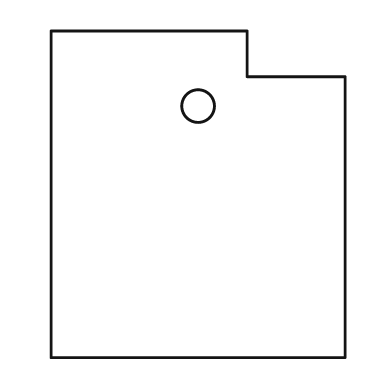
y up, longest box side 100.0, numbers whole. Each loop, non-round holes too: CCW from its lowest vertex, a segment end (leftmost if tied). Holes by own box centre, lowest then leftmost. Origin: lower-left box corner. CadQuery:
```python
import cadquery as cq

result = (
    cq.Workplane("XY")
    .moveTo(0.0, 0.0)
    .lineTo(90.0, 0.0)
    .lineTo(90.0, 86.0)
    .lineTo(60.0, 86.0)
    .lineTo(60.0, 100.0)
    .lineTo(0.0, 100.0)
    .close()
    .moveTo(45.0, 77.0)
    .circle(5.0)
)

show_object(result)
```